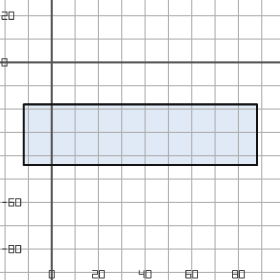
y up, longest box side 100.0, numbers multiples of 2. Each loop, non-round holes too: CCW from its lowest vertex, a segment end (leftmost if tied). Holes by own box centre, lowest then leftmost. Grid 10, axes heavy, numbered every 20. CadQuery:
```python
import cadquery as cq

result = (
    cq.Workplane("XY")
    .moveTo(-12.0, -44.0)
    .lineTo(88.0, -44.0)
    .lineTo(88.0, -18.0)
    .lineTo(-12.0, -18.0)
    .close()
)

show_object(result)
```